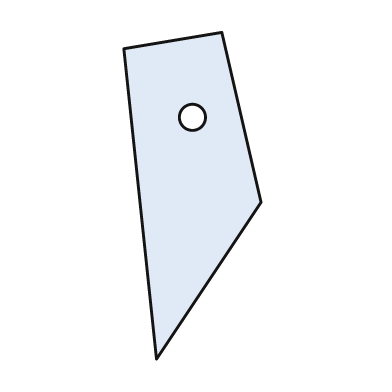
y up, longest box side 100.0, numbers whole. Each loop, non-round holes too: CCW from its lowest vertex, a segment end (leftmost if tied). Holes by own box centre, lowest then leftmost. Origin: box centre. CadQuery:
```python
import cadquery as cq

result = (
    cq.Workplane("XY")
    .moveTo(-11.0, -50.0)
    .lineTo(21.0, -2.0)
    .lineTo(9.0, 50.0)
    .lineTo(-21.0, 45.0)
    .close()
    .moveTo(0.0, 24.0)
    .circle(4.0)
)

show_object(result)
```